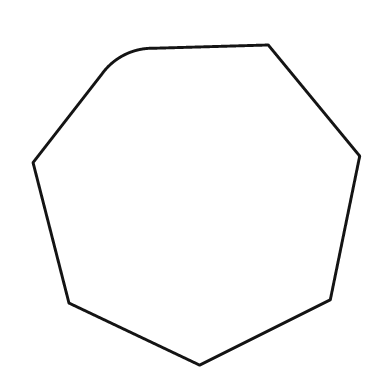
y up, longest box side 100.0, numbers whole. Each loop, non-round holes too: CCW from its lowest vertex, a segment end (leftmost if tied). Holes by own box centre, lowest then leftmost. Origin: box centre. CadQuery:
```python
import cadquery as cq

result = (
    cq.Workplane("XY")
    .moveTo(1.0, -49.0)
    .lineTo(41.0, -29.0)
    .lineTo(50.0, 15.0)
    .lineTo(22.0, 49.0)
    .lineTo(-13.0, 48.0)
    .threePointArc((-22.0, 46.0), (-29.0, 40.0))
    .lineTo(-50.0, 13.0)
    .lineTo(-39.0, -30.0)
    .close()
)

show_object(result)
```